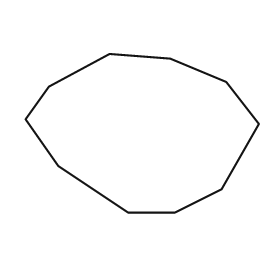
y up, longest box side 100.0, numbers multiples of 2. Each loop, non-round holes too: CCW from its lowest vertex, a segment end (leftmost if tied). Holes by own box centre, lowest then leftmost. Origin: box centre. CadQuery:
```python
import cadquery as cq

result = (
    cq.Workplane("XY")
    .moveTo(-6.0, -34.0)
    .lineTo(14.0, -34.0)
    .lineTo(34.0, -24.0)
    .lineTo(50.0, 4.0)
    .lineTo(36.0, 22.0)
    .lineTo(12.0, 32.0)
    .lineTo(-14.0, 34.0)
    .lineTo(-40.0, 20.0)
    .lineTo(-50.0, 6.0)
    .lineTo(-36.0, -14.0)
    .close()
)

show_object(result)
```